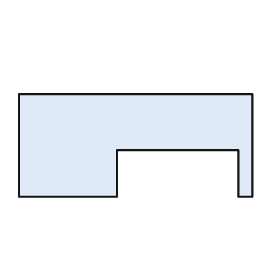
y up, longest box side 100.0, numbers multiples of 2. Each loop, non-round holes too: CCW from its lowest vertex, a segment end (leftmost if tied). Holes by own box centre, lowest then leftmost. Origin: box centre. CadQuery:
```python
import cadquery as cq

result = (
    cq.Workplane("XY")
    .moveTo(-50.0, -22.0)
    .lineTo(-8.0, -22.0)
    .lineTo(-8.0, -2.0)
    .lineTo(44.0, -2.0)
    .lineTo(44.0, -22.0)
    .lineTo(50.0, -22.0)
    .lineTo(50.0, 22.0)
    .lineTo(-50.0, 22.0)
    .close()
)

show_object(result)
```